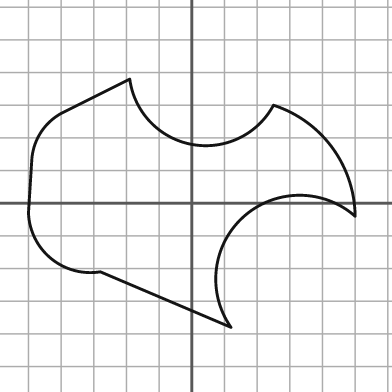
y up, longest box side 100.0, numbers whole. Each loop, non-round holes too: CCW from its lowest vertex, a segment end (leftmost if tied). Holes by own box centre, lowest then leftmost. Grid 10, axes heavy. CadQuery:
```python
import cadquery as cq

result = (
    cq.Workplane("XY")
    .moveTo(12.0, -38.0)
    .threePointArc((16.0, -4.0), (50.0, -4.0))
    .threePointArc((43.0, 17.0), (25.0, 30.0))
    .threePointArc((0.0, 18.0), (-19.0, 38.0))
    .lineTo(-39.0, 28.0)
    .threePointArc((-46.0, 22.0), (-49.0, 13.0))
    .lineTo(-50.0, -3.0)
    .threePointArc((-43.0, -17.0), (-28.0, -21.0))
    .close()
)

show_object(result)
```